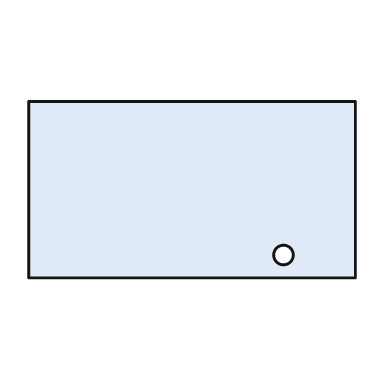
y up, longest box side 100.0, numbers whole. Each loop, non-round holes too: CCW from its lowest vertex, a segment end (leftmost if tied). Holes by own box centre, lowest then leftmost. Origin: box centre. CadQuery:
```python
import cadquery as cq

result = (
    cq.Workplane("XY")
    .moveTo(-50.0, -27.0)
    .lineTo(50.0, -27.0)
    .lineTo(50.0, 27.0)
    .lineTo(-50.0, 27.0)
    .close()
    .moveTo(28.0, -20.0)
    .circle(3.0)
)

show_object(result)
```